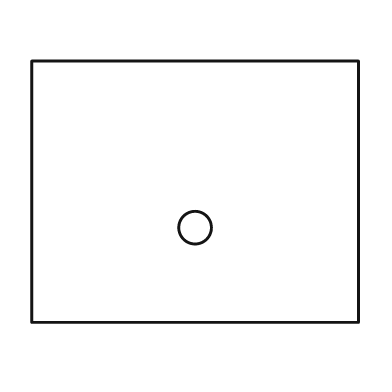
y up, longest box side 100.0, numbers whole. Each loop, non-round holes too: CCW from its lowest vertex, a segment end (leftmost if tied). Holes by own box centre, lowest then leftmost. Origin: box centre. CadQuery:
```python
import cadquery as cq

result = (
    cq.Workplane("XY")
    .moveTo(-50.0, -40.0)
    .lineTo(50.0, -40.0)
    .lineTo(50.0, 40.0)
    .lineTo(-50.0, 40.0)
    .close()
    .moveTo(0.0, -11.0)
    .circle(5.0)
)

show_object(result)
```